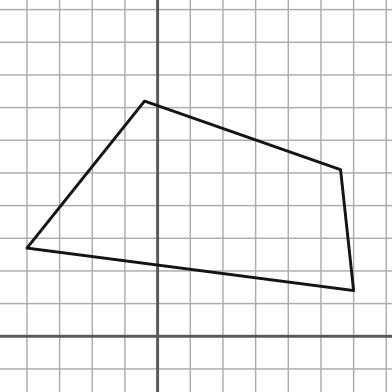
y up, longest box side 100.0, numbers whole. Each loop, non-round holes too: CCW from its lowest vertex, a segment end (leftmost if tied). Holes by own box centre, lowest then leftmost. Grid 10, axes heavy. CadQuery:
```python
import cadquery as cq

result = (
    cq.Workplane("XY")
    .moveTo(60.0, 14.0)
    .lineTo(56.0, 51.0)
    .lineTo(-4.0, 72.0)
    .lineTo(-40.0, 27.0)
    .close()
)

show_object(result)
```